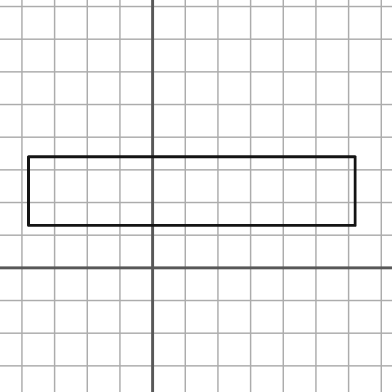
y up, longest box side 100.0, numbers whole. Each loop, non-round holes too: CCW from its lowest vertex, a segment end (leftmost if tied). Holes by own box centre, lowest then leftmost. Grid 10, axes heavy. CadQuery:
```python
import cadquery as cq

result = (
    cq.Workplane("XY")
    .moveTo(-38.0, 13.0)
    .lineTo(62.0, 13.0)
    .lineTo(62.0, 34.0)
    .lineTo(-38.0, 34.0)
    .close()
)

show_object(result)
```